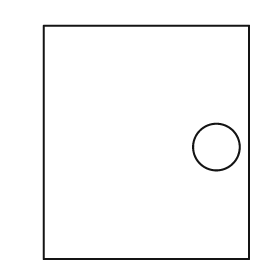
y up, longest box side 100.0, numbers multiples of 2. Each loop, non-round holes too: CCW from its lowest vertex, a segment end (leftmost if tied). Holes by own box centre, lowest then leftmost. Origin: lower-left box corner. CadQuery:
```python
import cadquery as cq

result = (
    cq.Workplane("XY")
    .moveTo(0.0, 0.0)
    .lineTo(88.0, 0.0)
    .lineTo(88.0, 100.0)
    .lineTo(0.0, 100.0)
    .close()
    .moveTo(74.0, 48.0)
    .circle(10.0)
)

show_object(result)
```